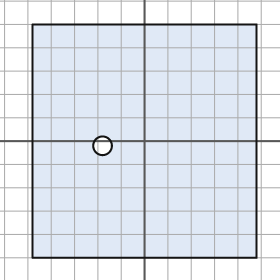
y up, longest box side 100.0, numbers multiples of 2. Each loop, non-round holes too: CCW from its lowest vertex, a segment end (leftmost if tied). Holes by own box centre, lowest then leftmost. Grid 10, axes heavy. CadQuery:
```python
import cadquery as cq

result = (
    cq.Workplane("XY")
    .moveTo(-48.0, -50.0)
    .lineTo(48.0, -50.0)
    .lineTo(48.0, 50.0)
    .lineTo(-48.0, 50.0)
    .close()
    .moveTo(-18.0, -2.0)
    .circle(4.0)
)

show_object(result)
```